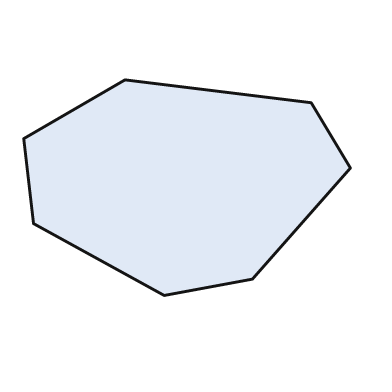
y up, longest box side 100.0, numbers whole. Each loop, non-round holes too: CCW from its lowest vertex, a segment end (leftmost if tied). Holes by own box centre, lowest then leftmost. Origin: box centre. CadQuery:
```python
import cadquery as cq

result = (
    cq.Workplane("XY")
    .moveTo(-7.0, -33.0)
    .lineTo(20.0, -28.0)
    .lineTo(50.0, 6.0)
    .lineTo(38.0, 26.0)
    .lineTo(-19.0, 33.0)
    .lineTo(-50.0, 15.0)
    .lineTo(-47.0, -11.0)
    .close()
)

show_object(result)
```